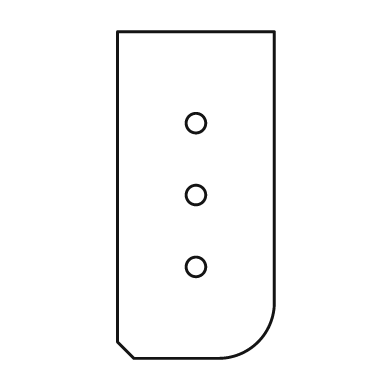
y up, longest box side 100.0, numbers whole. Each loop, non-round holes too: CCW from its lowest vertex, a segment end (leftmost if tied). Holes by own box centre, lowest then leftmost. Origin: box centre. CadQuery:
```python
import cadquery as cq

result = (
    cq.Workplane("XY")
    .moveTo(-19.0, -50.0)
    .lineTo(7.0, -50.0)
    .threePointArc((19.0, -45.0), (24.0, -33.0))
    .lineTo(24.0, 50.0)
    .lineTo(-24.0, 50.0)
    .lineTo(-24.0, -45.0)
    .close()
    .moveTo(0.0, -22.0)
    .circle(3.0)
    .moveTo(0.0, 0.0)
    .circle(3.0)
    .moveTo(0.0, 22.0)
    .circle(3.0)
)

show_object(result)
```